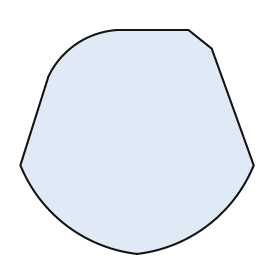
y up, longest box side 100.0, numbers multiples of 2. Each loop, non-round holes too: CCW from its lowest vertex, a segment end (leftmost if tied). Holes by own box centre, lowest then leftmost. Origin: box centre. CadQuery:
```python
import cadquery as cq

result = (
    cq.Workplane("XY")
    .moveTo(0.0, -48.0)
    .threePointArc((30.0, -36.0), (50.0, -10.0))
    .lineTo(32.0, 40.0)
    .lineTo(22.0, 48.0)
    .lineTo(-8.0, 48.0)
    .threePointArc((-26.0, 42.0), (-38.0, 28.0))
    .lineTo(-50.0, -10.0)
    .threePointArc((-30.0, -36.0), (0.0, -48.0))
    .close()
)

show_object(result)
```